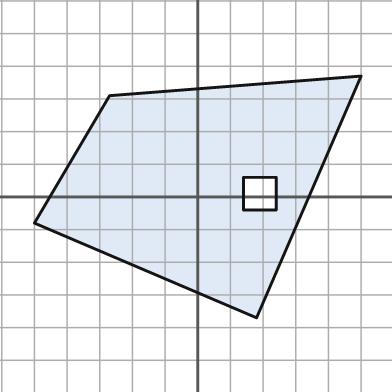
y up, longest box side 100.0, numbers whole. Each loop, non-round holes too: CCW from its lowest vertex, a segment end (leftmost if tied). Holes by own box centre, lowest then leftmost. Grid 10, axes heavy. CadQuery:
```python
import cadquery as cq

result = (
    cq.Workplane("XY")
    .moveTo(18.0, -37.0)
    .lineTo(50.0, 37.0)
    .lineTo(-27.0, 31.0)
    .lineTo(-50.0, -8.0)
    .close()
    .moveTo(14.0, -4.0)
    .lineTo(24.0, -4.0)
    .lineTo(24.0, 6.0)
    .lineTo(14.0, 6.0)
    .close()
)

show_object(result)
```